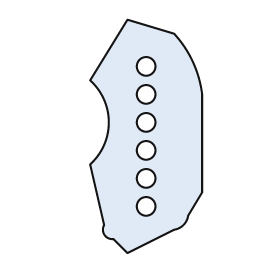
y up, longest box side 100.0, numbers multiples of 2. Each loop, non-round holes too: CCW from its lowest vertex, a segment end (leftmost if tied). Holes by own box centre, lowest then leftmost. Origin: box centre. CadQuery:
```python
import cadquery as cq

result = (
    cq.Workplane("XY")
    .moveTo(-8.0, -50.0)
    .lineTo(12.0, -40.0)
    .threePointArc((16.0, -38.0), (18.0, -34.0))
    .lineTo(24.0, -24.0)
    .lineTo(24.0, 18.0)
    .threePointArc((20.0, 32.0), (12.0, 44.0))
    .lineTo(-8.0, 50.0)
    .lineTo(-24.0, 24.0)
    .threePointArc((-16.0, 6.0), (-24.0, -12.0))
    .lineTo(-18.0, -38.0)
    .threePointArc((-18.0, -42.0), (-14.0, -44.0))
    .close()
    .moveTo(0.0, -30.0)
    .circle(4.0)
    .moveTo(0.0, -18.0)
    .circle(4.0)
    .moveTo(0.0, -6.0)
    .circle(4.0)
    .moveTo(0.0, 6.0)
    .circle(4.0)
    .moveTo(0.0, 18.0)
    .circle(4.0)
    .moveTo(0.0, 30.0)
    .circle(4.0)
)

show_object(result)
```